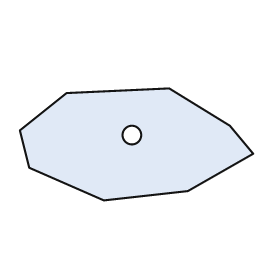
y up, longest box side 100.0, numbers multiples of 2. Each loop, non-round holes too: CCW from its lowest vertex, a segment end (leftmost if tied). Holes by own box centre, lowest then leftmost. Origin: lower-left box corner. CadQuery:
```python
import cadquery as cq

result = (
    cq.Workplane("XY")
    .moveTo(36.0, 0.0)
    .lineTo(72.0, 4.0)
    .lineTo(100.0, 20.0)
    .lineTo(90.0, 32.0)
    .lineTo(64.0, 48.0)
    .lineTo(20.0, 46.0)
    .lineTo(0.0, 30.0)
    .lineTo(4.0, 14.0)
    .close()
    .moveTo(48.0, 28.0)
    .circle(4.0)
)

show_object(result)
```